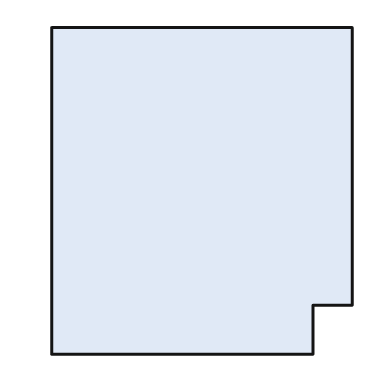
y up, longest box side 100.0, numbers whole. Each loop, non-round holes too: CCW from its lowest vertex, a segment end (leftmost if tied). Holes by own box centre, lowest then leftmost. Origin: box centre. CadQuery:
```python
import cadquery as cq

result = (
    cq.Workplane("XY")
    .moveTo(-46.0, -50.0)
    .lineTo(34.0, -50.0)
    .lineTo(34.0, -35.0)
    .lineTo(46.0, -35.0)
    .lineTo(46.0, 50.0)
    .lineTo(-46.0, 50.0)
    .close()
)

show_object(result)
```